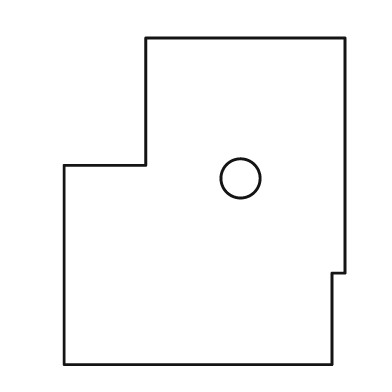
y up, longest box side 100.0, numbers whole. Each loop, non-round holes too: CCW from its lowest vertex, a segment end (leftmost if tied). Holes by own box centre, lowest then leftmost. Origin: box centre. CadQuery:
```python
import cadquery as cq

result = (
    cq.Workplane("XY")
    .moveTo(-43.0, -50.0)
    .lineTo(39.0, -50.0)
    .lineTo(39.0, -22.0)
    .lineTo(43.0, -22.0)
    .lineTo(43.0, 50.0)
    .lineTo(-18.0, 50.0)
    .lineTo(-18.0, 11.0)
    .lineTo(-43.0, 11.0)
    .close()
    .moveTo(11.0, 7.0)
    .circle(6.0)
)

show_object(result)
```